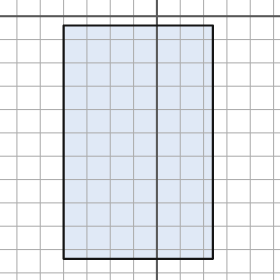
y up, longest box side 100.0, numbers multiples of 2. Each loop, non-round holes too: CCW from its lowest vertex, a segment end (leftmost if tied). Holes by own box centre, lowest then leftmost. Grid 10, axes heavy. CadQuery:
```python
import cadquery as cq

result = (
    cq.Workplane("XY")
    .moveTo(-40.0, -104.0)
    .lineTo(24.0, -104.0)
    .lineTo(24.0, -4.0)
    .lineTo(-40.0, -4.0)
    .close()
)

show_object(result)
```